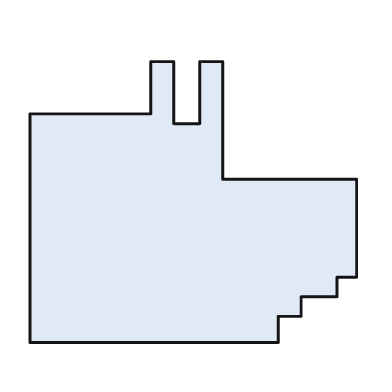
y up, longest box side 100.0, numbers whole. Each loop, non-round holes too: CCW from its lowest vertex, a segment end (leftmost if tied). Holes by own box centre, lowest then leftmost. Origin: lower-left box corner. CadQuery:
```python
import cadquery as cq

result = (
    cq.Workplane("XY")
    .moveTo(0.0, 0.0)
    .lineTo(76.0, 0.0)
    .lineTo(76.0, 8.0)
    .lineTo(83.0, 8.0)
    .lineTo(83.0, 14.0)
    .lineTo(94.0, 14.0)
    .lineTo(94.0, 20.0)
    .lineTo(100.0, 20.0)
    .lineTo(100.0, 50.0)
    .lineTo(59.0, 50.0)
    .lineTo(59.0, 86.0)
    .lineTo(52.0, 86.0)
    .lineTo(52.0, 67.0)
    .lineTo(44.0, 67.0)
    .lineTo(44.0, 86.0)
    .lineTo(37.0, 86.0)
    .lineTo(37.0, 70.0)
    .lineTo(0.0, 70.0)
    .close()
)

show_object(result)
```